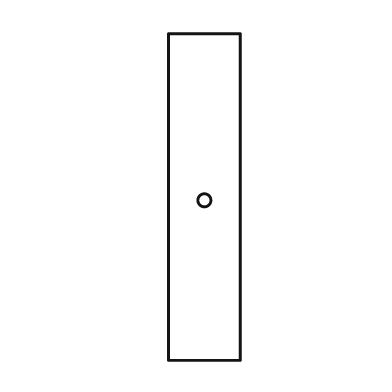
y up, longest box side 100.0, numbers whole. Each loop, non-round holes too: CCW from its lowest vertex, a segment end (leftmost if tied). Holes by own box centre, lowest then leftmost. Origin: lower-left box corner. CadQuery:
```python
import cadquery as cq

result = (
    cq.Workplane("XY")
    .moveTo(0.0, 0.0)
    .lineTo(22.0, 0.0)
    .lineTo(22.0, 100.0)
    .lineTo(0.0, 100.0)
    .close()
    .moveTo(11.0, 49.0)
    .circle(2.0)
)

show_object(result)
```